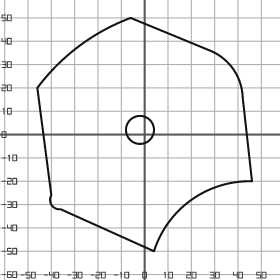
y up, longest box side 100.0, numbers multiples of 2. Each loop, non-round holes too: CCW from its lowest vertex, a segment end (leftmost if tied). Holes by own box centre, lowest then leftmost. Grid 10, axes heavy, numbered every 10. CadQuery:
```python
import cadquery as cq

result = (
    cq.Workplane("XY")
    .moveTo(4.0, -50.0)
    .threePointArc((20.0, -28.0), (46.0, -20.0))
    .lineTo(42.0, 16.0)
    .threePointArc((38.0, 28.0), (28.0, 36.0))
    .lineTo(-6.0, 50.0)
    .threePointArc((-28.0, 38.0), (-46.0, 20.0))
    .lineTo(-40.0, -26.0)
    .threePointArc((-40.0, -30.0), (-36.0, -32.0))
    .close()
    .moveTo(-2.0, 2.0)
    .circle(6.0)
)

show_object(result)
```